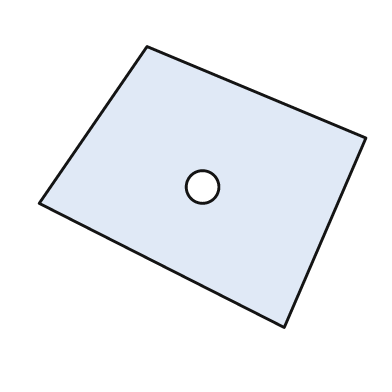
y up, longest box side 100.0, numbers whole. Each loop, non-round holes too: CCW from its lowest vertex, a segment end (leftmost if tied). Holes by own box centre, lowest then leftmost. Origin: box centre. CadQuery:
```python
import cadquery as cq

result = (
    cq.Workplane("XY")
    .moveTo(25.0, -43.0)
    .lineTo(50.0, 15.0)
    .lineTo(-17.0, 43.0)
    .lineTo(-50.0, -5.0)
    .close()
    .moveTo(0.0, 0.0)
    .circle(5.0)
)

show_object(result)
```